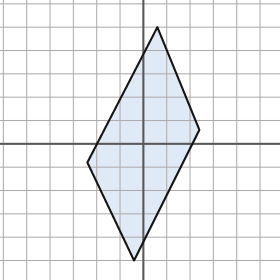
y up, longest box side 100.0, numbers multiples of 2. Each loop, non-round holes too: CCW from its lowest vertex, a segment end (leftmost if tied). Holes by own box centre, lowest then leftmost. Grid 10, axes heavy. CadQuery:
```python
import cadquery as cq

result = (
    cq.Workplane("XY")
    .moveTo(-4.0, -50.0)
    .lineTo(24.0, 6.0)
    .lineTo(6.0, 50.0)
    .lineTo(-24.0, -8.0)
    .close()
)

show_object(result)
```